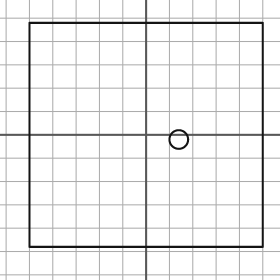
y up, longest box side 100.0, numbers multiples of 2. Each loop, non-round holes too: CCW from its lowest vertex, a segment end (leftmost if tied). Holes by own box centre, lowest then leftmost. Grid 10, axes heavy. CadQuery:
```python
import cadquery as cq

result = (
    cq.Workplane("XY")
    .moveTo(-50.0, -48.0)
    .lineTo(50.0, -48.0)
    .lineTo(50.0, 48.0)
    .lineTo(-50.0, 48.0)
    .close()
    .moveTo(14.0, -2.0)
    .circle(4.0)
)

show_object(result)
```